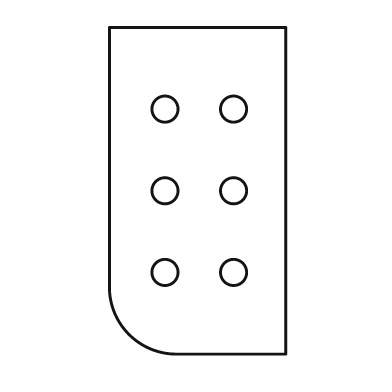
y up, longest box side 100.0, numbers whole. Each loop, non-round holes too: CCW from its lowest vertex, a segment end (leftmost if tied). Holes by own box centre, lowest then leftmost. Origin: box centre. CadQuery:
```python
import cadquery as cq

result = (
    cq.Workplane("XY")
    .moveTo(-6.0, -50.0)
    .lineTo(27.0, -50.0)
    .lineTo(27.0, 50.0)
    .lineTo(-27.0, 50.0)
    .lineTo(-27.0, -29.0)
    .threePointArc((-21.0, -44.0), (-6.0, -50.0))
    .close()
    .moveTo(-10.0, -25.0)
    .circle(4.0)
    .moveTo(11.0, -25.0)
    .circle(4.0)
    .moveTo(-10.0, 0.0)
    .circle(4.0)
    .moveTo(11.0, 0.0)
    .circle(4.0)
    .moveTo(-10.0, 25.0)
    .circle(4.0)
    .moveTo(11.0, 25.0)
    .circle(4.0)
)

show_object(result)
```